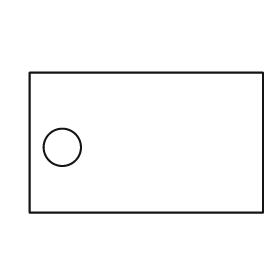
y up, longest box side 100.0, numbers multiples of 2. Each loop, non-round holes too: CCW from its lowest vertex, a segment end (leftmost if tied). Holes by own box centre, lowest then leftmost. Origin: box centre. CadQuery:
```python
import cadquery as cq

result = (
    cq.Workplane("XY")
    .moveTo(-50.0, -30.0)
    .lineTo(50.0, -30.0)
    .lineTo(50.0, 30.0)
    .lineTo(-50.0, 30.0)
    .close()
    .moveTo(-36.0, -2.0)
    .circle(8.0)
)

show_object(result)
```